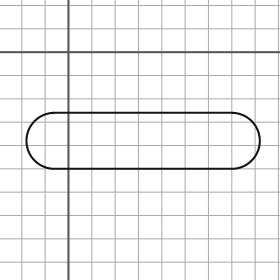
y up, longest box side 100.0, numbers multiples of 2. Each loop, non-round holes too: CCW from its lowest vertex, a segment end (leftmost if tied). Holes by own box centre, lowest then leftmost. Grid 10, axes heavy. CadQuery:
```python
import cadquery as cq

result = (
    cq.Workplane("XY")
    .moveTo(-6.0, -50.0)
    .lineTo(70.0, -50.0)
    .threePointArc((82.0, -38.0), (70.0, -26.0))
    .lineTo(-6.0, -26.0)
    .threePointArc((-18.0, -38.0), (-6.0, -50.0))
    .close()
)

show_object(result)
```